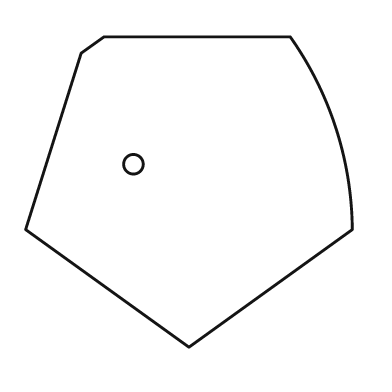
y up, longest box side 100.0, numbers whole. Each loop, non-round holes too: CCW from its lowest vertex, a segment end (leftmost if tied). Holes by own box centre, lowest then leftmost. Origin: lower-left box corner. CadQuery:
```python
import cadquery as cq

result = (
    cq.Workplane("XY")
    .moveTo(50.0, 0.0)
    .lineTo(100.0, 36.0)
    .threePointArc((95.0, 67.0), (81.0, 95.0))
    .lineTo(24.0, 95.0)
    .lineTo(17.0, 90.0)
    .lineTo(0.0, 36.0)
    .close()
    .moveTo(33.0, 56.0)
    .circle(3.0)
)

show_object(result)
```